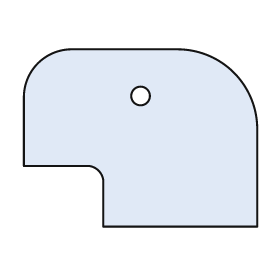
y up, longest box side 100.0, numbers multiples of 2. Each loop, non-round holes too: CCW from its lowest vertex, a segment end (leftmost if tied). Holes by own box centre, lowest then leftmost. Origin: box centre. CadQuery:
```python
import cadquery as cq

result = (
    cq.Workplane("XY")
    .moveTo(-16.0, -38.0)
    .lineTo(50.0, -38.0)
    .lineTo(50.0, 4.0)
    .threePointArc((40.0, 28.0), (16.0, 38.0))
    .lineTo(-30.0, 38.0)
    .threePointArc((-44.0, 32.0), (-50.0, 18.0))
    .lineTo(-50.0, -12.0)
    .lineTo(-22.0, -12.0)
    .threePointArc((-18.0, -14.0), (-16.0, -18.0))
    .close()
    .moveTo(0.0, 18.0)
    .circle(4.0)
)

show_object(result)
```